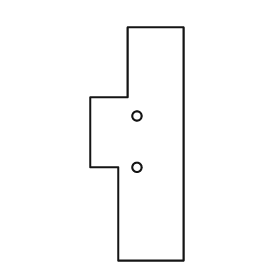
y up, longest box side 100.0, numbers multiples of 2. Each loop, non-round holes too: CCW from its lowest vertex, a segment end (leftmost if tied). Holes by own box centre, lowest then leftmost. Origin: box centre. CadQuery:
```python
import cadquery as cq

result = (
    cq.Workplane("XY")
    .moveTo(-8.0, -50.0)
    .lineTo(20.0, -50.0)
    .lineTo(20.0, 50.0)
    .lineTo(-4.0, 50.0)
    .lineTo(-4.0, 20.0)
    .lineTo(-20.0, 20.0)
    .lineTo(-20.0, -10.0)
    .lineTo(-8.0, -10.0)
    .close()
    .moveTo(0.0, -10.0)
    .circle(2.0)
    .moveTo(0.0, 12.0)
    .circle(2.0)
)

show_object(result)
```